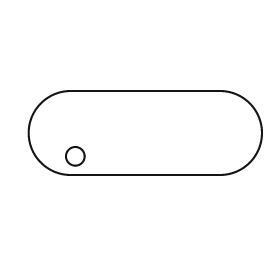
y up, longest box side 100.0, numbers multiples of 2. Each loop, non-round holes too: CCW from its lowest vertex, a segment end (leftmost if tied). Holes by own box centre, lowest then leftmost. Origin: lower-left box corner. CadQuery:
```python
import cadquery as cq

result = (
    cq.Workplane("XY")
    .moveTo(18.0, 0.0)
    .lineTo(82.0, 0.0)
    .threePointArc((100.0, 18.0), (82.0, 36.0))
    .lineTo(18.0, 36.0)
    .threePointArc((0.0, 18.0), (18.0, 0.0))
    .close()
    .moveTo(20.0, 8.0)
    .circle(4.0)
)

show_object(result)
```